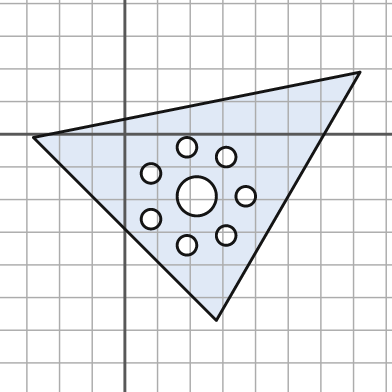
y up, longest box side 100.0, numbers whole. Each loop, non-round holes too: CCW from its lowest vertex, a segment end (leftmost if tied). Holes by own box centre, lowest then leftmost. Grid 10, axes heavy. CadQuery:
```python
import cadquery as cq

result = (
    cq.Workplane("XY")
    .moveTo(28.0, -57.0)
    .lineTo(72.0, 19.0)
    .lineTo(-28.0, -1.0)
    .close()
    .moveTo(19.0, -34.0)
    .circle(3.0)
    .moveTo(31.0, -31.0)
    .circle(3.0)
    .moveTo(8.0, -26.0)
    .circle(3.0)
    .moveTo(22.0, -19.0)
    .circle(6.0)
    .moveTo(37.0, -19.0)
    .circle(3.0)
    .moveTo(8.0, -12.0)
    .circle(3.0)
    .moveTo(31.0, -7.0)
    .circle(3.0)
    .moveTo(19.0, -4.0)
    .circle(3.0)
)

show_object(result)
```